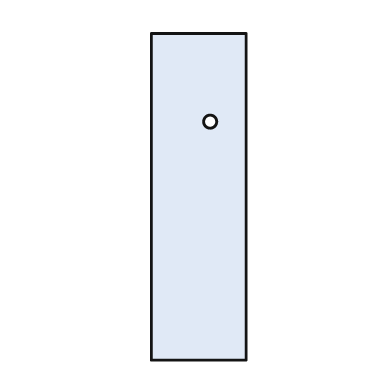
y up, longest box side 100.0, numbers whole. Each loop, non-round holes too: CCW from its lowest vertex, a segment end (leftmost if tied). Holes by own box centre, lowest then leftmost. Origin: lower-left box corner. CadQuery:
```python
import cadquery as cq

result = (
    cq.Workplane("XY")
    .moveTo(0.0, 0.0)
    .lineTo(29.0, 0.0)
    .lineTo(29.0, 100.0)
    .lineTo(0.0, 100.0)
    .close()
    .moveTo(18.0, 73.0)
    .circle(2.0)
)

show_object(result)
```